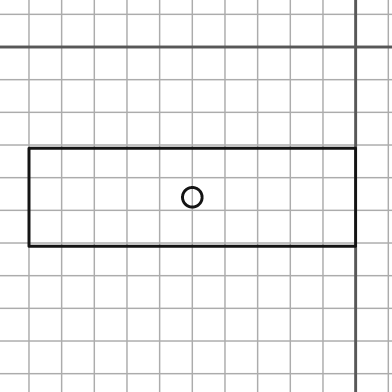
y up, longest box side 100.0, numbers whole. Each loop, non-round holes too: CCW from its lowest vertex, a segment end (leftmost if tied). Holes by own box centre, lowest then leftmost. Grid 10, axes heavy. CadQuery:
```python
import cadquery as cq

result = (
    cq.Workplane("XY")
    .moveTo(-100.0, -61.0)
    .lineTo(0.0, -61.0)
    .lineTo(0.0, -31.0)
    .lineTo(-100.0, -31.0)
    .close()
    .moveTo(-50.0, -46.0)
    .circle(3.0)
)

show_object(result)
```